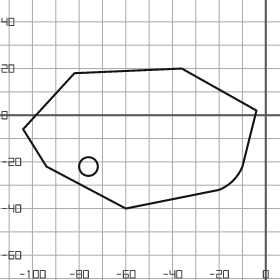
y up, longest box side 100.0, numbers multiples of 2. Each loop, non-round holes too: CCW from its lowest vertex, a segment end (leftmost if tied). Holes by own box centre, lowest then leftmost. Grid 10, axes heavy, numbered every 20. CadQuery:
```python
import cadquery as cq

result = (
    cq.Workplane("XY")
    .moveTo(-60.0, -40.0)
    .lineTo(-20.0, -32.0)
    .threePointArc((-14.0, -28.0), (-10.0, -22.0))
    .lineTo(-4.0, 2.0)
    .lineTo(-36.0, 20.0)
    .lineTo(-82.0, 18.0)
    .lineTo(-104.0, -6.0)
    .lineTo(-94.0, -22.0)
    .close()
    .moveTo(-76.0, -22.0)
    .circle(4.0)
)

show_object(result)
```